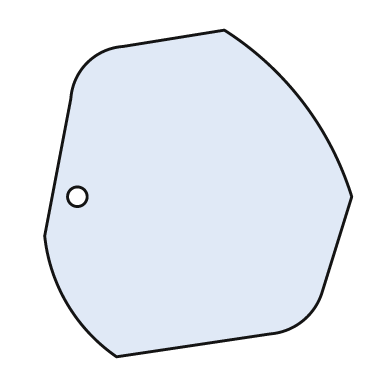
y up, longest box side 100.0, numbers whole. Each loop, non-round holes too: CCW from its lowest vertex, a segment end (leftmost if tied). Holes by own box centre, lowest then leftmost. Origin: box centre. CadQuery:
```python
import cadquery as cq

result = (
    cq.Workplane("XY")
    .moveTo(-25.0, -50.0)
    .lineTo(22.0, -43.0)
    .threePointArc((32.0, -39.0), (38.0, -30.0))
    .lineTo(47.0, -1.0)
    .threePointArc((32.0, 28.0), (8.0, 50.0))
    .lineTo(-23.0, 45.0)
    .threePointArc((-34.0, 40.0), (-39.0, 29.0))
    .lineTo(-47.0, -13.0)
    .threePointArc((-40.0, -34.0), (-25.0, -50.0))
    .close()
    .moveTo(-37.0, -1.0)
    .circle(3.0)
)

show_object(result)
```